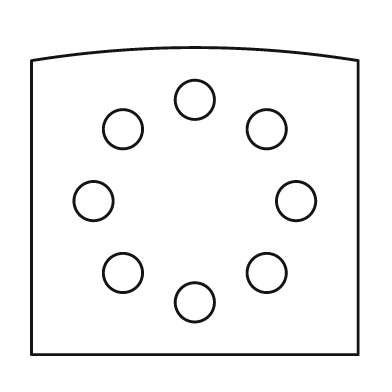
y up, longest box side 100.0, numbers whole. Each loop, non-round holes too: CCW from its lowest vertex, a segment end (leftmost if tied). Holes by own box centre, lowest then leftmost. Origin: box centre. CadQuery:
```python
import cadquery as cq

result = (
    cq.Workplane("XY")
    .moveTo(-50.0, -47.0)
    .lineTo(50.0, -47.0)
    .lineTo(50.0, 43.0)
    .threePointArc((0.0, 47.0), (-50.0, 43.0))
    .close()
    .moveTo(0.0, -31.0)
    .circle(6.0)
    .moveTo(-22.0, -22.0)
    .circle(6.0)
    .moveTo(22.0, -22.0)
    .circle(6.0)
    .moveTo(-31.0, 0.0)
    .circle(6.0)
    .moveTo(31.0, 0.0)
    .circle(6.0)
    .moveTo(-22.0, 22.0)
    .circle(6.0)
    .moveTo(22.0, 22.0)
    .circle(6.0)
    .moveTo(0.0, 31.0)
    .circle(6.0)
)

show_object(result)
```